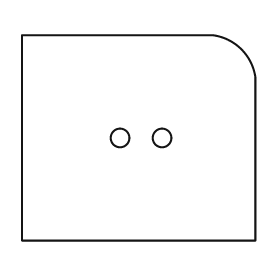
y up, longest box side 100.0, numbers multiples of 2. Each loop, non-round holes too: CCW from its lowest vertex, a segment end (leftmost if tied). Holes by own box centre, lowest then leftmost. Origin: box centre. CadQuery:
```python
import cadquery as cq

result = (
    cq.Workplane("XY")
    .moveTo(-50.0, -44.0)
    .lineTo(50.0, -44.0)
    .lineTo(50.0, 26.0)
    .threePointArc((44.0, 38.0), (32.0, 44.0))
    .lineTo(-50.0, 44.0)
    .close()
    .moveTo(-8.0, 0.0)
    .circle(4.0)
    .moveTo(10.0, 0.0)
    .circle(4.0)
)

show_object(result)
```